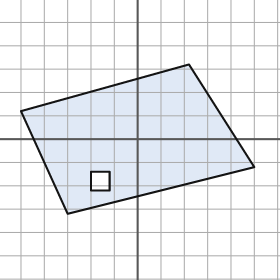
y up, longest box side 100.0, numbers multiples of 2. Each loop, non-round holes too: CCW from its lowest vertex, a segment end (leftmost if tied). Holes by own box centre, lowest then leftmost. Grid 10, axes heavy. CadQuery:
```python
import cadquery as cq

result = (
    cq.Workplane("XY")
    .moveTo(-30.0, -32.0)
    .lineTo(50.0, -12.0)
    .lineTo(22.0, 32.0)
    .lineTo(-50.0, 12.0)
    .close()
    .moveTo(-20.0, -22.0)
    .lineTo(-12.0, -22.0)
    .lineTo(-12.0, -14.0)
    .lineTo(-20.0, -14.0)
    .close()
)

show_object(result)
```